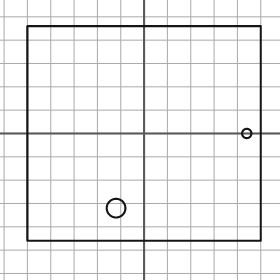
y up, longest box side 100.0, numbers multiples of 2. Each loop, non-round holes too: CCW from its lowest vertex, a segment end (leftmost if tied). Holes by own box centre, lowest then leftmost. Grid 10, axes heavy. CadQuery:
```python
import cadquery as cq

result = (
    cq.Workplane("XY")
    .moveTo(-50.0, -46.0)
    .lineTo(50.0, -46.0)
    .lineTo(50.0, 46.0)
    .lineTo(-50.0, 46.0)
    .close()
    .moveTo(-12.0, -32.0)
    .circle(4.0)
    .moveTo(44.0, 0.0)
    .circle(2.0)
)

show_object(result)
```